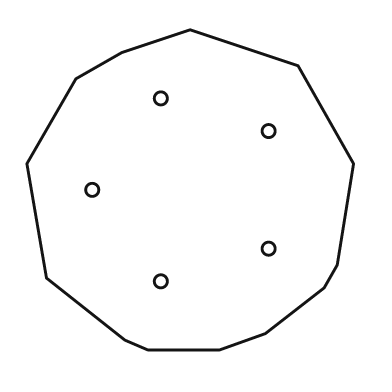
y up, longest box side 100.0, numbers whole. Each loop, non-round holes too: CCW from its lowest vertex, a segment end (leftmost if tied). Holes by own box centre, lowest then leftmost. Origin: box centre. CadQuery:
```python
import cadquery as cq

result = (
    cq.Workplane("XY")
    .moveTo(-13.0, -49.0)
    .lineTo(9.0, -49.0)
    .lineTo(23.0, -44.0)
    .lineTo(41.0, -30.0)
    .lineTo(45.0, -23.0)
    .lineTo(50.0, 8.0)
    .lineTo(33.0, 38.0)
    .lineTo(0.0, 49.0)
    .lineTo(-21.0, 42.0)
    .lineTo(-35.0, 34.0)
    .lineTo(-50.0, 8.0)
    .lineTo(-44.0, -27.0)
    .lineTo(-20.0, -46.0)
    .close()
    .moveTo(-9.0, -28.0)
    .circle(2.0)
    .moveTo(24.0, -18.0)
    .circle(2.0)
    .moveTo(-30.0, 0.0)
    .circle(2.0)
    .moveTo(24.0, 18.0)
    .circle(2.0)
    .moveTo(-9.0, 28.0)
    .circle(2.0)
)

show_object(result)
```